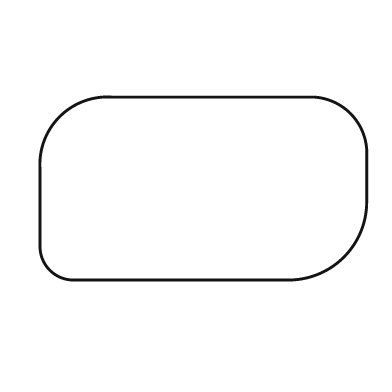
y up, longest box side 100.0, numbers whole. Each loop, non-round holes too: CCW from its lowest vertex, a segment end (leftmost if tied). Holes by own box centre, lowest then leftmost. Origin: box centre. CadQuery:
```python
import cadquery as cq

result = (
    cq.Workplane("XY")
    .moveTo(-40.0, -28.0)
    .lineTo(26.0, -28.0)
    .threePointArc((43.0, -21.0), (50.0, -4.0))
    .lineTo(50.0, 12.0)
    .threePointArc((45.0, 23.0), (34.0, 28.0))
    .lineTo(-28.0, 28.0)
    .threePointArc((-44.0, 22.0), (-50.0, 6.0))
    .lineTo(-50.0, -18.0)
    .threePointArc((-47.0, -25.0), (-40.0, -28.0))
    .close()
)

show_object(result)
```